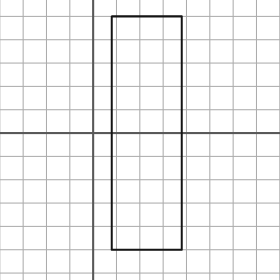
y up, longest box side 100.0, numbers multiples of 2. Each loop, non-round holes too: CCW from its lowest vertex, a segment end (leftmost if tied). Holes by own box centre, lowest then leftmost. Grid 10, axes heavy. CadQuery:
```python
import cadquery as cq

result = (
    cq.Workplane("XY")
    .moveTo(8.0, -50.0)
    .lineTo(38.0, -50.0)
    .lineTo(38.0, 50.0)
    .lineTo(8.0, 50.0)
    .close()
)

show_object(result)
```